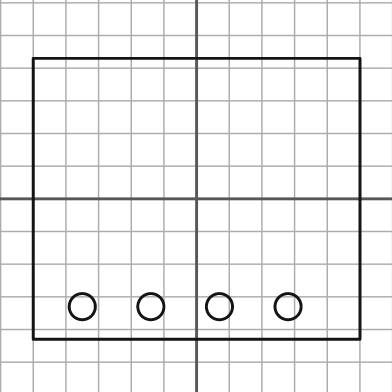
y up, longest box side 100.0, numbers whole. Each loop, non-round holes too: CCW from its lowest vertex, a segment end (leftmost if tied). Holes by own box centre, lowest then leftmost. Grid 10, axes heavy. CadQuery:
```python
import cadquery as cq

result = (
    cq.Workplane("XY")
    .moveTo(-50.0, -43.0)
    .lineTo(50.0, -43.0)
    .lineTo(50.0, 43.0)
    .lineTo(-50.0, 43.0)
    .close()
    .moveTo(-35.0, -33.0)
    .circle(4.0)
    .moveTo(-14.0, -33.0)
    .circle(4.0)
    .moveTo(7.0, -33.0)
    .circle(4.0)
    .moveTo(28.0, -33.0)
    .circle(4.0)
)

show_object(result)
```